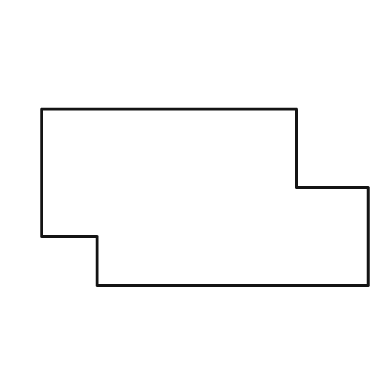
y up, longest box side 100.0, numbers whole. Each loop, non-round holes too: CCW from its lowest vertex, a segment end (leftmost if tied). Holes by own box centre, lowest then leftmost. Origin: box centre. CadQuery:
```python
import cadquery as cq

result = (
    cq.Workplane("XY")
    .moveTo(-33.0, -27.0)
    .lineTo(50.0, -27.0)
    .lineTo(50.0, 3.0)
    .lineTo(28.0, 3.0)
    .lineTo(28.0, 27.0)
    .lineTo(-50.0, 27.0)
    .lineTo(-50.0, -12.0)
    .lineTo(-33.0, -12.0)
    .close()
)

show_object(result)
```